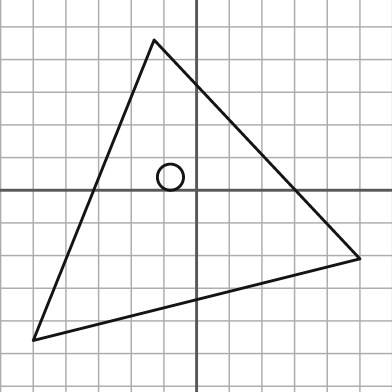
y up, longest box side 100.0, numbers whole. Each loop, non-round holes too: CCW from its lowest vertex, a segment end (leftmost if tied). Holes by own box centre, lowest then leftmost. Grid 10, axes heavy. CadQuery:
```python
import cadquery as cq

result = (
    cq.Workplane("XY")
    .moveTo(-50.0, -46.0)
    .lineTo(50.0, -21.0)
    .lineTo(-13.0, 46.0)
    .close()
    .moveTo(-8.0, 4.0)
    .circle(4.0)
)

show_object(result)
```